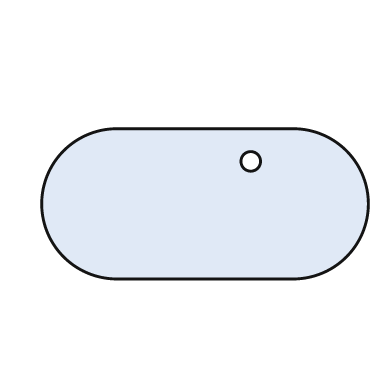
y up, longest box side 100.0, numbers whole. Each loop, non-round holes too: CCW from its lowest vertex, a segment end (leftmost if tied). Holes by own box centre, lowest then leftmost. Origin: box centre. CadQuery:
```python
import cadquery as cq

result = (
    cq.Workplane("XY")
    .moveTo(-27.0, -23.0)
    .lineTo(27.0, -23.0)
    .threePointArc((50.0, 0.0), (27.0, 23.0))
    .lineTo(-27.0, 23.0)
    .threePointArc((-50.0, 0.0), (-27.0, -23.0))
    .close()
    .moveTo(14.0, 13.0)
    .circle(3.0)
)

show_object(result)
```